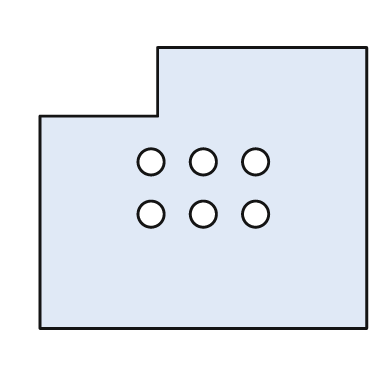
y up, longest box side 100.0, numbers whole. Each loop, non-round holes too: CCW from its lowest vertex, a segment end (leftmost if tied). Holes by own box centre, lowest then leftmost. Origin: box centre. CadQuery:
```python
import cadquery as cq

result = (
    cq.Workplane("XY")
    .moveTo(-50.0, -43.0)
    .lineTo(50.0, -43.0)
    .lineTo(50.0, 43.0)
    .lineTo(-14.0, 43.0)
    .lineTo(-14.0, 22.0)
    .lineTo(-50.0, 22.0)
    .close()
    .moveTo(-16.0, -8.0)
    .circle(4.0)
    .moveTo(0.0, -8.0)
    .circle(4.0)
    .moveTo(16.0, -8.0)
    .circle(4.0)
    .moveTo(-16.0, 8.0)
    .circle(4.0)
    .moveTo(0.0, 8.0)
    .circle(4.0)
    .moveTo(16.0, 8.0)
    .circle(4.0)
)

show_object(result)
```